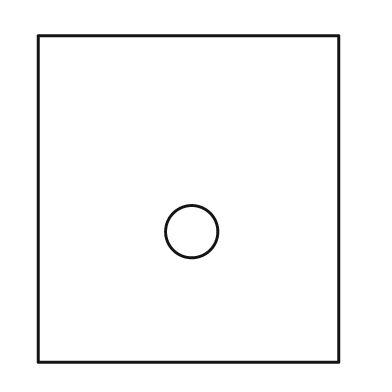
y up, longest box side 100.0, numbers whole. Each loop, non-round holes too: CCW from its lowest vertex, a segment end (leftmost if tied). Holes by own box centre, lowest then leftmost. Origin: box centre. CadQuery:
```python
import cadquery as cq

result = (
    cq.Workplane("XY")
    .moveTo(-46.0, -50.0)
    .lineTo(46.0, -50.0)
    .lineTo(46.0, 50.0)
    .lineTo(-46.0, 50.0)
    .close()
    .moveTo(1.0, -10.0)
    .circle(8.0)
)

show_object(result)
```